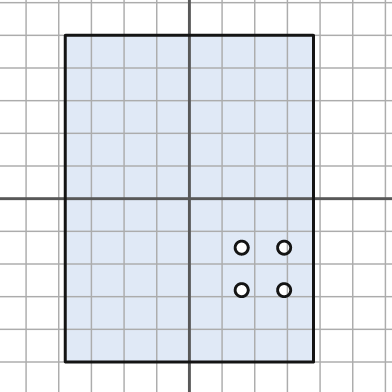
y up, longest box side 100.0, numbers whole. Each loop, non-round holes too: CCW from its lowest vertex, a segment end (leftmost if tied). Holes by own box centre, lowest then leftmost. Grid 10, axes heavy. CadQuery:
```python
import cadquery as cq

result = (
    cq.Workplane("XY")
    .moveTo(-38.0, -50.0)
    .lineTo(38.0, -50.0)
    .lineTo(38.0, 50.0)
    .lineTo(-38.0, 50.0)
    .close()
    .moveTo(16.0, -28.0)
    .circle(2.0)
    .moveTo(29.0, -28.0)
    .circle(2.0)
    .moveTo(16.0, -15.0)
    .circle(2.0)
    .moveTo(29.0, -15.0)
    .circle(2.0)
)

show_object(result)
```